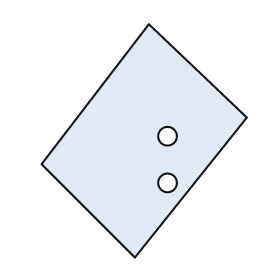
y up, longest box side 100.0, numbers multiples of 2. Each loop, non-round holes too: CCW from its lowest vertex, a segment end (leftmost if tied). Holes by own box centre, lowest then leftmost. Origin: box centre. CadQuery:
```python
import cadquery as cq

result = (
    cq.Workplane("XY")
    .moveTo(-4.0, -50.0)
    .lineTo(44.0, 10.0)
    .lineTo(2.0, 50.0)
    .lineTo(-44.0, -10.0)
    .close()
    .moveTo(10.0, -18.0)
    .circle(4.0)
    .moveTo(10.0, 2.0)
    .circle(4.0)
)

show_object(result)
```